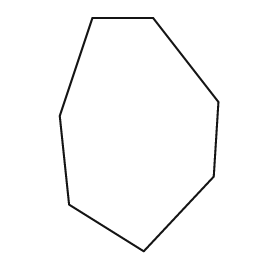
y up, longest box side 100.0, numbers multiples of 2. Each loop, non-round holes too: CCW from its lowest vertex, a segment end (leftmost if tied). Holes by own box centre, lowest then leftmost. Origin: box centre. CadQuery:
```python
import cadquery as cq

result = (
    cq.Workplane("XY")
    .moveTo(2.0, -50.0)
    .lineTo(32.0, -18.0)
    .lineTo(34.0, 14.0)
    .lineTo(6.0, 50.0)
    .lineTo(-20.0, 50.0)
    .lineTo(-34.0, 8.0)
    .lineTo(-30.0, -30.0)
    .close()
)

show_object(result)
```